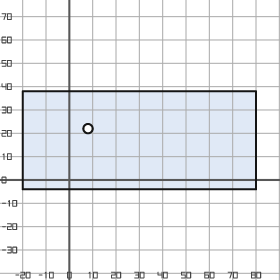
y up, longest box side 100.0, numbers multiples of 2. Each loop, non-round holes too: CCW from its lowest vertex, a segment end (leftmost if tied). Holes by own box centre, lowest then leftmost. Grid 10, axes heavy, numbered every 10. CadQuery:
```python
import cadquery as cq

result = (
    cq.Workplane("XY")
    .moveTo(-20.0, -4.0)
    .lineTo(80.0, -4.0)
    .lineTo(80.0, 38.0)
    .lineTo(-20.0, 38.0)
    .close()
    .moveTo(8.0, 22.0)
    .circle(2.0)
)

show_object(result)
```